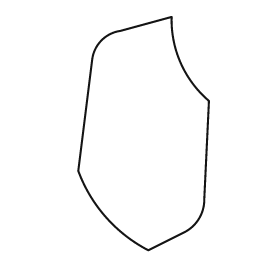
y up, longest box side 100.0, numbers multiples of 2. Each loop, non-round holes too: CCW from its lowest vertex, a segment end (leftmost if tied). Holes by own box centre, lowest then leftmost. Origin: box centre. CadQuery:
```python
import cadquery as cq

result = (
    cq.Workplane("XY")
    .moveTo(2.0, -50.0)
    .lineTo(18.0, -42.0)
    .threePointArc((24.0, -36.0), (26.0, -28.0))
    .lineTo(28.0, 14.0)
    .threePointArc((16.0, 30.0), (12.0, 50.0))
    .lineTo(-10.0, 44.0)
    .threePointArc((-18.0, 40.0), (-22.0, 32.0))
    .lineTo(-28.0, -16.0)
    .threePointArc((-16.0, -36.0), (2.0, -50.0))
    .close()
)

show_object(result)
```